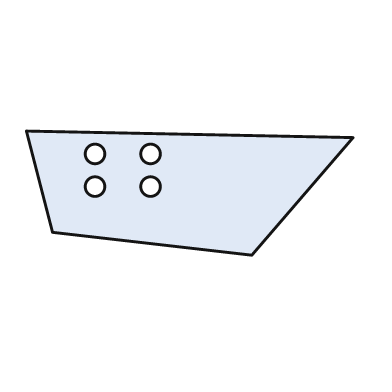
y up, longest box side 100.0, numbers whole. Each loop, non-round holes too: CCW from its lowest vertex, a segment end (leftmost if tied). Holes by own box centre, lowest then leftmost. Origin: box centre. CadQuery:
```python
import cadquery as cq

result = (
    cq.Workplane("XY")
    .moveTo(19.0, -19.0)
    .lineTo(50.0, 17.0)
    .lineTo(-50.0, 19.0)
    .lineTo(-42.0, -12.0)
    .close()
    .moveTo(-29.0, 2.0)
    .circle(3.0)
    .moveTo(-12.0, 2.0)
    .circle(3.0)
    .moveTo(-29.0, 12.0)
    .circle(3.0)
    .moveTo(-12.0, 12.0)
    .circle(3.0)
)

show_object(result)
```